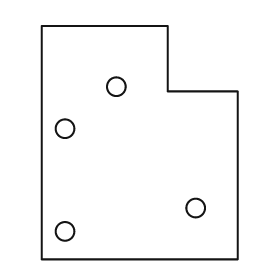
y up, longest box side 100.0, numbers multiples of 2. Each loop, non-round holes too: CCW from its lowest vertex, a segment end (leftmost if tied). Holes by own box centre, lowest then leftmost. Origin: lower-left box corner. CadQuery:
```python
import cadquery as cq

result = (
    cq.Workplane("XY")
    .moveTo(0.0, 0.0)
    .lineTo(84.0, 0.0)
    .lineTo(84.0, 72.0)
    .lineTo(54.0, 72.0)
    .lineTo(54.0, 100.0)
    .lineTo(0.0, 100.0)
    .close()
    .moveTo(10.0, 12.0)
    .circle(4.0)
    .moveTo(66.0, 22.0)
    .circle(4.0)
    .moveTo(10.0, 56.0)
    .circle(4.0)
    .moveTo(32.0, 74.0)
    .circle(4.0)
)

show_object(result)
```